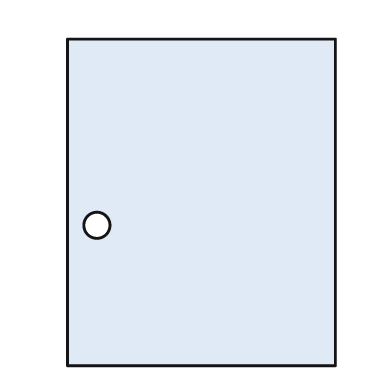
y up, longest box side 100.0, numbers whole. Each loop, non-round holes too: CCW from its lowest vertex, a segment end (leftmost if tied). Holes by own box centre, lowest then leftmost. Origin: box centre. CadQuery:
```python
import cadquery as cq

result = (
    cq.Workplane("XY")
    .moveTo(-41.0, -50.0)
    .lineTo(41.0, -50.0)
    .lineTo(41.0, 50.0)
    .lineTo(-41.0, 50.0)
    .close()
    .moveTo(-32.0, -7.0)
    .circle(4.0)
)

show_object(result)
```